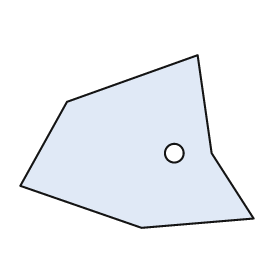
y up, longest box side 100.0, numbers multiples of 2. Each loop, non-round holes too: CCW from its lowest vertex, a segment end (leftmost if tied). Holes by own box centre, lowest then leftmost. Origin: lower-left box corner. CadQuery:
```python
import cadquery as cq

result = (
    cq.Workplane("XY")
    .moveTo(52.0, 0.0)
    .lineTo(100.0, 4.0)
    .lineTo(82.0, 32.0)
    .lineTo(76.0, 74.0)
    .lineTo(20.0, 54.0)
    .lineTo(0.0, 18.0)
    .close()
    .moveTo(66.0, 32.0)
    .circle(4.0)
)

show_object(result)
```